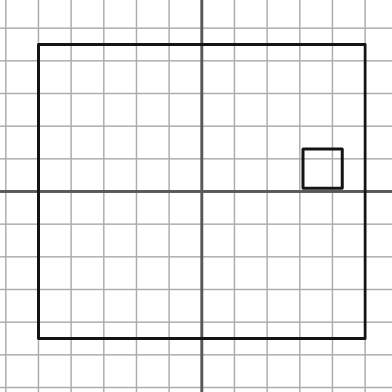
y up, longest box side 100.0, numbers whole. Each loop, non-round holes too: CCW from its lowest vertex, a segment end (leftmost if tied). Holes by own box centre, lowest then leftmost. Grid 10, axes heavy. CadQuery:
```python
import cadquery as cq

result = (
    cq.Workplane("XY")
    .moveTo(-50.0, -45.0)
    .lineTo(50.0, -45.0)
    .lineTo(50.0, 45.0)
    .lineTo(-50.0, 45.0)
    .close()
    .moveTo(31.0, 1.0)
    .lineTo(43.0, 1.0)
    .lineTo(43.0, 13.0)
    .lineTo(31.0, 13.0)
    .close()
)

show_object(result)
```